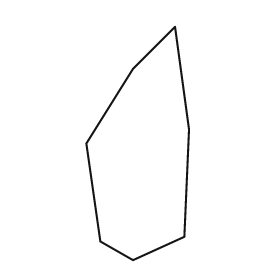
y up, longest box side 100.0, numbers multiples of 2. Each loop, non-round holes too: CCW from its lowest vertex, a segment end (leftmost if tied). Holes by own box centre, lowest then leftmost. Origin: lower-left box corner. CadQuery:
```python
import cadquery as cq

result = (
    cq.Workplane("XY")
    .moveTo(20.0, 0.0)
    .lineTo(42.0, 10.0)
    .lineTo(44.0, 56.0)
    .lineTo(38.0, 100.0)
    .lineTo(20.0, 82.0)
    .lineTo(0.0, 50.0)
    .lineTo(6.0, 8.0)
    .close()
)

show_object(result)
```